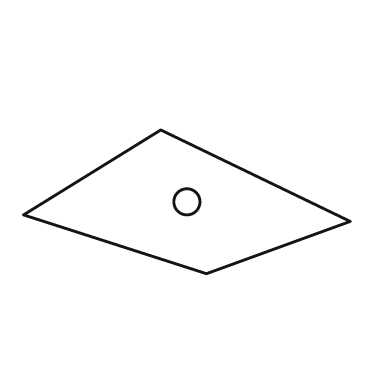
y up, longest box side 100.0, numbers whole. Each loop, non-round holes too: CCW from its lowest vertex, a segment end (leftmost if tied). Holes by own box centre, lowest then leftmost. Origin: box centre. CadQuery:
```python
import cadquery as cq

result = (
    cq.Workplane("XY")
    .moveTo(6.0, -22.0)
    .lineTo(50.0, -6.0)
    .lineTo(-8.0, 22.0)
    .lineTo(-50.0, -4.0)
    .close()
    .moveTo(0.0, 0.0)
    .circle(4.0)
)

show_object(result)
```